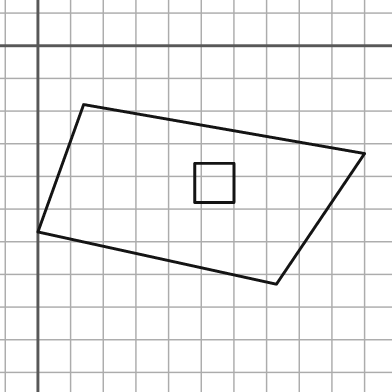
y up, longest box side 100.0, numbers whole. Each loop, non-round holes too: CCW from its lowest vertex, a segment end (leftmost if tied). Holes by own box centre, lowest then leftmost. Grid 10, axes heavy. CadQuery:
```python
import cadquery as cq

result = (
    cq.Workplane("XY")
    .moveTo(73.0, -73.0)
    .lineTo(100.0, -33.0)
    .lineTo(14.0, -18.0)
    .lineTo(0.0, -57.0)
    .close()
    .moveTo(48.0, -48.0)
    .lineTo(60.0, -48.0)
    .lineTo(60.0, -36.0)
    .lineTo(48.0, -36.0)
    .close()
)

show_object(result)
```